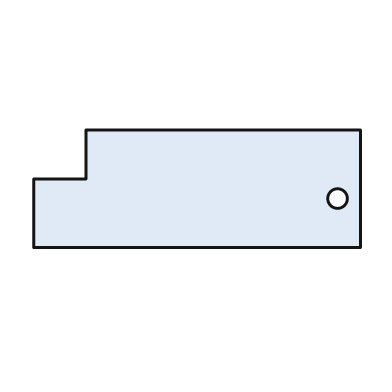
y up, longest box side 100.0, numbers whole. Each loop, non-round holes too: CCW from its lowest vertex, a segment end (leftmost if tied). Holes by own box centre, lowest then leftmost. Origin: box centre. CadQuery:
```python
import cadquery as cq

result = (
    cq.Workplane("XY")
    .moveTo(-50.0, -18.0)
    .lineTo(50.0, -18.0)
    .lineTo(50.0, 18.0)
    .lineTo(-34.0, 18.0)
    .lineTo(-34.0, 3.0)
    .lineTo(-50.0, 3.0)
    .close()
    .moveTo(43.0, -3.0)
    .circle(3.0)
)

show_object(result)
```